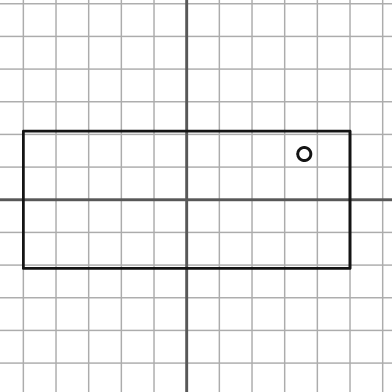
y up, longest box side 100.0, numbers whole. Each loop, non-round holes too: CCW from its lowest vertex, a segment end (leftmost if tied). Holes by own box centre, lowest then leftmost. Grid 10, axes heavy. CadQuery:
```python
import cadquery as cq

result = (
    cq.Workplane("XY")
    .moveTo(-50.0, -21.0)
    .lineTo(50.0, -21.0)
    .lineTo(50.0, 21.0)
    .lineTo(-50.0, 21.0)
    .close()
    .moveTo(36.0, 14.0)
    .circle(2.0)
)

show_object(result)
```